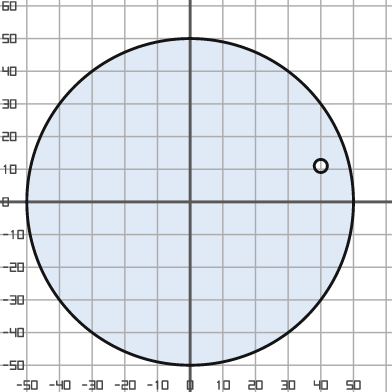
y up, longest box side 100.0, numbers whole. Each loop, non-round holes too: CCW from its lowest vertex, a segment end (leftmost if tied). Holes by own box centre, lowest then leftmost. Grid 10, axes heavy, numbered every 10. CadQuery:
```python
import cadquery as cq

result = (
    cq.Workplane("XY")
    .moveTo(0.0, 0.0)
    .circle(50.0)
    .moveTo(40.0, 11.0)
    .circle(2.0)
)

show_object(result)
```